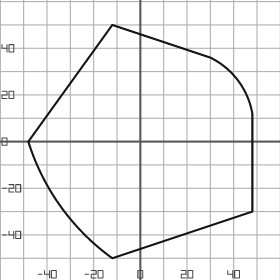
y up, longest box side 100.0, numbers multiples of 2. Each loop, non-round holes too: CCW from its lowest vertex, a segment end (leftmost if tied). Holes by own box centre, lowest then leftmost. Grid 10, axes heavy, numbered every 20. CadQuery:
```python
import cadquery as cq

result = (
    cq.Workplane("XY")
    .moveTo(-12.0, -50.0)
    .lineTo(48.0, -30.0)
    .lineTo(48.0, 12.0)
    .threePointArc((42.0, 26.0), (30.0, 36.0))
    .lineTo(-12.0, 50.0)
    .lineTo(-48.0, 0.0)
    .threePointArc((-34.0, -28.0), (-12.0, -50.0))
    .close()
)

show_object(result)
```